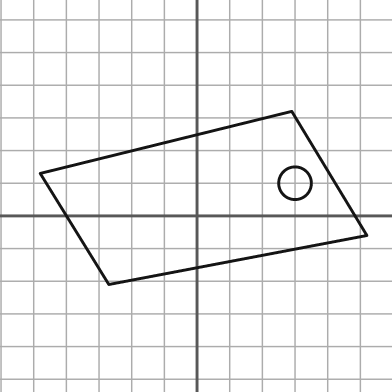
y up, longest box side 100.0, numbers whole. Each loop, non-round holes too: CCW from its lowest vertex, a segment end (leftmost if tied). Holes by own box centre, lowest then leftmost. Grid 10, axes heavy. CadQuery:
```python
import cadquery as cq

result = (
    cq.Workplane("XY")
    .moveTo(-27.0, -21.0)
    .lineTo(52.0, -6.0)
    .lineTo(29.0, 32.0)
    .lineTo(-48.0, 13.0)
    .close()
    .moveTo(30.0, 10.0)
    .circle(5.0)
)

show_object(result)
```